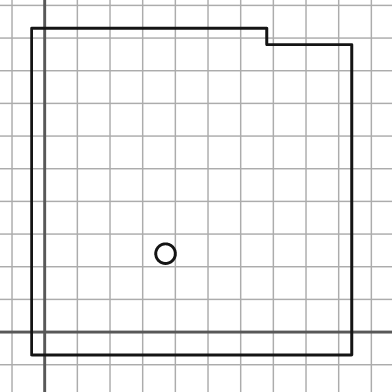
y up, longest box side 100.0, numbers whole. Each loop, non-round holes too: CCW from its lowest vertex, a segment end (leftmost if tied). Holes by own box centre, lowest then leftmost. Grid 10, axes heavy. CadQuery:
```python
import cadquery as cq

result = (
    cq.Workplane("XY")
    .moveTo(-4.0, -7.0)
    .lineTo(94.0, -7.0)
    .lineTo(94.0, 88.0)
    .lineTo(68.0, 88.0)
    .lineTo(68.0, 93.0)
    .lineTo(-4.0, 93.0)
    .close()
    .moveTo(37.0, 24.0)
    .circle(3.0)
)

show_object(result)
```